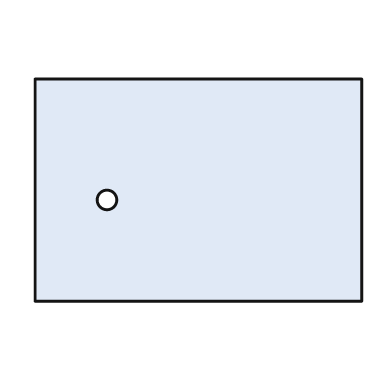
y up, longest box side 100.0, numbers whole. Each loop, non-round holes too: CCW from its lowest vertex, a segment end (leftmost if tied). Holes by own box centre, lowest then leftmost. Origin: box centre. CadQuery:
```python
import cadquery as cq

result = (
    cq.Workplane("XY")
    .moveTo(-50.0, -34.0)
    .lineTo(50.0, -34.0)
    .lineTo(50.0, 34.0)
    .lineTo(-50.0, 34.0)
    .close()
    .moveTo(-28.0, -3.0)
    .circle(3.0)
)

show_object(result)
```